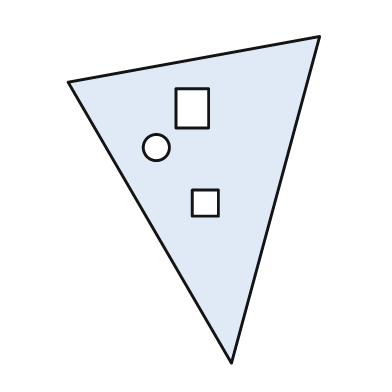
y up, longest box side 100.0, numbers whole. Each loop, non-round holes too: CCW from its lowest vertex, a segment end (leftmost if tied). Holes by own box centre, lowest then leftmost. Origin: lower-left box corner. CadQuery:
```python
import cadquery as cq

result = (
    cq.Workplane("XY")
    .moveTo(50.0, 0.0)
    .lineTo(77.0, 100.0)
    .lineTo(0.0, 86.0)
    .close()
    .moveTo(38.0, 45.0)
    .lineTo(46.0, 45.0)
    .lineTo(46.0, 53.0)
    .lineTo(38.0, 53.0)
    .close()
    .moveTo(27.0, 66.0)
    .circle(4.0)
    .moveTo(33.0, 72.0)
    .lineTo(43.0, 72.0)
    .lineTo(43.0, 84.0)
    .lineTo(33.0, 84.0)
    .close()
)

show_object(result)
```